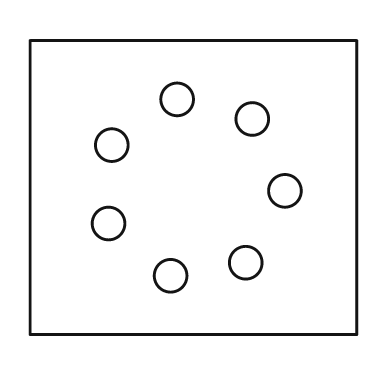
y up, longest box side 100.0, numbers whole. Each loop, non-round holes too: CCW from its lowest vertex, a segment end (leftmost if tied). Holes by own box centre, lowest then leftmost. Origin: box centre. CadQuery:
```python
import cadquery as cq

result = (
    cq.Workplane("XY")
    .moveTo(-50.0, -45.0)
    .lineTo(50.0, -45.0)
    .lineTo(50.0, 45.0)
    .lineTo(-50.0, 45.0)
    .close()
    .moveTo(-7.0, -27.0)
    .circle(5.0)
    .moveTo(16.0, -23.0)
    .circle(5.0)
    .moveTo(-26.0, -11.0)
    .circle(5.0)
    .moveTo(28.0, -1.0)
    .circle(5.0)
    .moveTo(-25.0, 13.0)
    .circle(5.0)
    .moveTo(18.0, 21.0)
    .circle(5.0)
    .moveTo(-5.0, 27.0)
    .circle(5.0)
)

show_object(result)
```